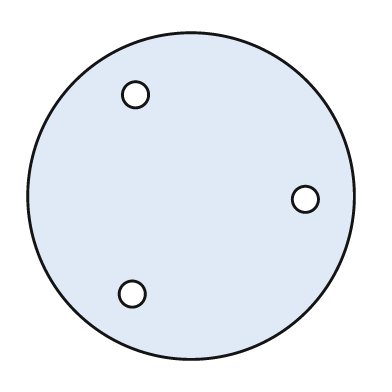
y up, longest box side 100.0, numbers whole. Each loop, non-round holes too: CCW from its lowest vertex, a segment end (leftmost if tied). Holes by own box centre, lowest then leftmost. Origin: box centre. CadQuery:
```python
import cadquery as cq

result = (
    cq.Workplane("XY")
    .moveTo(0.0, 0.0)
    .circle(50.0)
    .moveTo(-18.0, -30.0)
    .circle(4.0)
    .moveTo(35.0, -1.0)
    .circle(4.0)
    .moveTo(-17.0, 31.0)
    .circle(4.0)
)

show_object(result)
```